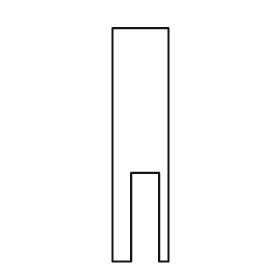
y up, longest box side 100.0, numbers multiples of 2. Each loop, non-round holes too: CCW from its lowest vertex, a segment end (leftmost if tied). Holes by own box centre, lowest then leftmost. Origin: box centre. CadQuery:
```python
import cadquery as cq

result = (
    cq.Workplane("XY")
    .moveTo(-12.0, -50.0)
    .lineTo(-4.0, -50.0)
    .lineTo(-4.0, -12.0)
    .lineTo(8.0, -12.0)
    .lineTo(8.0, -50.0)
    .lineTo(12.0, -50.0)
    .lineTo(12.0, 50.0)
    .lineTo(-12.0, 50.0)
    .close()
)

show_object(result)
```